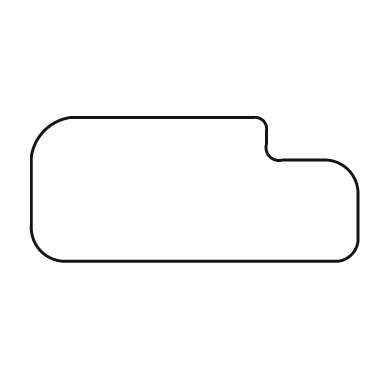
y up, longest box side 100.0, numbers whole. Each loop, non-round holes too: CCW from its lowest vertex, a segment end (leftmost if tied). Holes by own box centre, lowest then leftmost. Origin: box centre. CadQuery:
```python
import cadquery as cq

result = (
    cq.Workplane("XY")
    .moveTo(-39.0, -22.0)
    .lineTo(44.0, -22.0)
    .threePointArc((48.0, -20.0), (50.0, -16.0))
    .lineTo(50.0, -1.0)
    .threePointArc((47.0, 6.0), (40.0, 9.0))
    .lineTo(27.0, 9.0)
    .threePointArc((23.0, 10.0), (22.0, 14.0))
    .lineTo(22.0, 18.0)
    .threePointArc((21.0, 21.0), (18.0, 22.0))
    .lineTo(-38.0, 22.0)
    .threePointArc((-46.0, 18.0), (-50.0, 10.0))
    .lineTo(-50.0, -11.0)
    .threePointArc((-47.0, -19.0), (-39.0, -22.0))
    .close()
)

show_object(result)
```